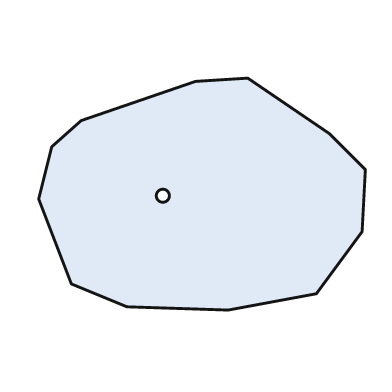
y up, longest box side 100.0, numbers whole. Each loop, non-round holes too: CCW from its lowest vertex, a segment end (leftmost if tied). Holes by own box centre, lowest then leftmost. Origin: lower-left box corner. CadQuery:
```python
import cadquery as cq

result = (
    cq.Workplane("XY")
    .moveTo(58.0, 0.0)
    .lineTo(85.0, 5.0)
    .lineTo(99.0, 24.0)
    .lineTo(100.0, 43.0)
    .lineTo(89.0, 54.0)
    .lineTo(64.0, 71.0)
    .lineTo(48.0, 70.0)
    .lineTo(13.0, 58.0)
    .lineTo(4.0, 50.0)
    .lineTo(0.0, 34.0)
    .lineTo(10.0, 8.0)
    .lineTo(27.0, 1.0)
    .close()
    .moveTo(38.0, 35.0)
    .circle(2.0)
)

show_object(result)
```